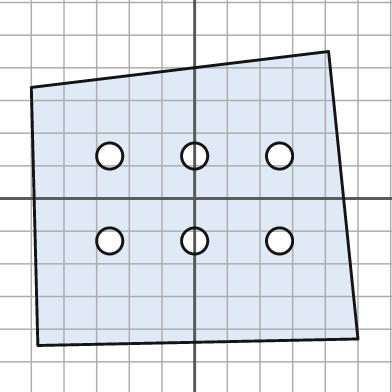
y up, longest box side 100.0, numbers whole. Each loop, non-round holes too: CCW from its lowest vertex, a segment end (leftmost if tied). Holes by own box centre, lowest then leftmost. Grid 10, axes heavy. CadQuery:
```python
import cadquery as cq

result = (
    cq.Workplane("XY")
    .moveTo(-48.0, -45.0)
    .lineTo(50.0, -43.0)
    .lineTo(41.0, 45.0)
    .lineTo(-50.0, 34.0)
    .close()
    .moveTo(-26.0, -13.0)
    .circle(4.0)
    .moveTo(0.0, -13.0)
    .circle(4.0)
    .moveTo(26.0, -13.0)
    .circle(4.0)
    .moveTo(-26.0, 13.0)
    .circle(4.0)
    .moveTo(0.0, 13.0)
    .circle(4.0)
    .moveTo(26.0, 13.0)
    .circle(4.0)
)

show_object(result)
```